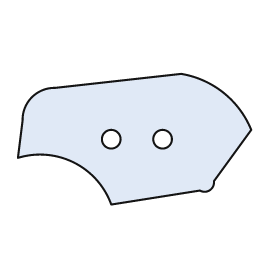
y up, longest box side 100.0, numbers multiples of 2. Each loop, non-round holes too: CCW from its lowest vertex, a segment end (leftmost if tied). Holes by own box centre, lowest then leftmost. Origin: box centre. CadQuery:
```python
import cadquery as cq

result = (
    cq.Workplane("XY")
    .moveTo(-10.0, -28.0)
    .lineTo(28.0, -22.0)
    .threePointArc((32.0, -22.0), (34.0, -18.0))
    .lineTo(50.0, 4.0)
    .threePointArc((38.0, 20.0), (20.0, 28.0))
    .lineTo(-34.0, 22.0)
    .threePointArc((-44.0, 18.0), (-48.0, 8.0))
    .lineTo(-50.0, -8.0)
    .threePointArc((-26.0, -10.0), (-10.0, -28.0))
    .close()
    .moveTo(-10.0, 0.0)
    .circle(4.0)
    .moveTo(12.0, 0.0)
    .circle(4.0)
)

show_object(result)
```